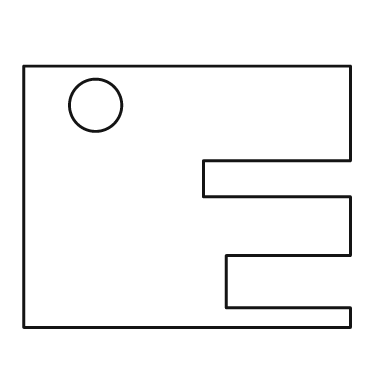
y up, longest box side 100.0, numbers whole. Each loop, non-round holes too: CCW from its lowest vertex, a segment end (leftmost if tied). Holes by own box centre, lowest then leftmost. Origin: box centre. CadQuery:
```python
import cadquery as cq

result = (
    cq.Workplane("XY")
    .moveTo(-50.0, -40.0)
    .lineTo(50.0, -40.0)
    .lineTo(50.0, -34.0)
    .lineTo(12.0, -34.0)
    .lineTo(12.0, -18.0)
    .lineTo(50.0, -18.0)
    .lineTo(50.0, 0.0)
    .lineTo(5.0, 0.0)
    .lineTo(5.0, 11.0)
    .lineTo(50.0, 11.0)
    .lineTo(50.0, 40.0)
    .lineTo(-50.0, 40.0)
    .close()
    .moveTo(-28.0, 28.0)
    .circle(8.0)
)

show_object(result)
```